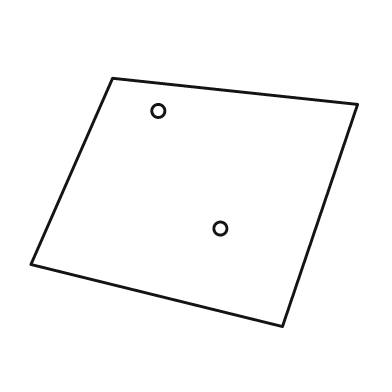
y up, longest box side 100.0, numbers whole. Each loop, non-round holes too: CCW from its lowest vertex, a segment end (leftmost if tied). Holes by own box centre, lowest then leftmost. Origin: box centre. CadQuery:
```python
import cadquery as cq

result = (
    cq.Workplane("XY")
    .moveTo(27.0, -38.0)
    .lineTo(50.0, 30.0)
    .lineTo(-25.0, 38.0)
    .lineTo(-50.0, -19.0)
    .close()
    .moveTo(8.0, -8.0)
    .circle(2.0)
    .moveTo(-11.0, 28.0)
    .circle(2.0)
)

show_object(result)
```